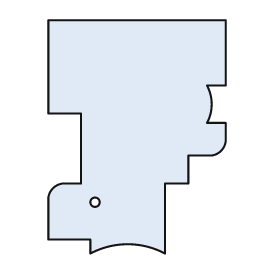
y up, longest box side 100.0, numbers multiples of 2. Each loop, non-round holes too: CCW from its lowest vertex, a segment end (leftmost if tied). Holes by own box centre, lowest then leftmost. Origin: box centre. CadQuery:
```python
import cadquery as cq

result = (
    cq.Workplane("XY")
    .moveTo(-20.0, -50.0)
    .threePointArc((-4.0, -46.0), (12.0, -50.0))
    .lineTo(12.0, -20.0)
    .lineTo(22.0, -20.0)
    .lineTo(22.0, -8.0)
    .lineTo(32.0, -8.0)
    .threePointArc((36.0, -6.0), (38.0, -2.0))
    .lineTo(38.0, 6.0)
    .lineTo(30.0, 6.0)
    .threePointArc((32.0, 14.0), (30.0, 22.0))
    .lineTo(38.0, 22.0)
    .lineTo(38.0, 50.0)
    .lineTo(-38.0, 50.0)
    .lineTo(-38.0, 10.0)
    .lineTo(-24.0, 10.0)
    .lineTo(-24.0, -20.0)
    .lineTo(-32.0, -20.0)
    .threePointArc((-36.0, -22.0), (-38.0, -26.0))
    .lineTo(-38.0, -44.0)
    .lineTo(-20.0, -44.0)
    .close()
    .moveTo(-18.0, -28.0)
    .circle(2.0)
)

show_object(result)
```